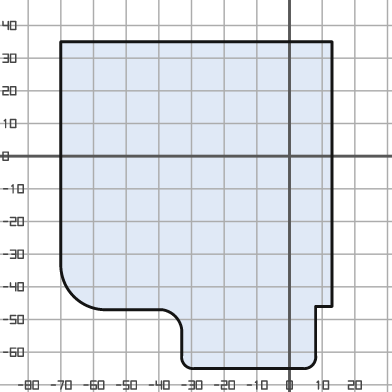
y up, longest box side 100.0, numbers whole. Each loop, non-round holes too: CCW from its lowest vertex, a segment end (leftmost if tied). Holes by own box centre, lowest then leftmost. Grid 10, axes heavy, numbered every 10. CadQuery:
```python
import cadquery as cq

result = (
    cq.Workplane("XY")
    .moveTo(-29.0, -65.0)
    .lineTo(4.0, -65.0)
    .threePointArc((7.0, -64.0), (8.0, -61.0))
    .lineTo(8.0, -46.0)
    .lineTo(13.0, -46.0)
    .lineTo(13.0, 35.0)
    .lineTo(-70.0, 35.0)
    .lineTo(-70.0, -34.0)
    .threePointArc((-66.0, -43.0), (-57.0, -47.0))
    .lineTo(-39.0, -47.0)
    .threePointArc((-35.0, -49.0), (-33.0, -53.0))
    .lineTo(-33.0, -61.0)
    .threePointArc((-32.0, -64.0), (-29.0, -65.0))
    .close()
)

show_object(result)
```